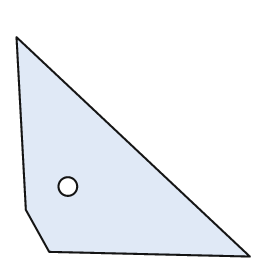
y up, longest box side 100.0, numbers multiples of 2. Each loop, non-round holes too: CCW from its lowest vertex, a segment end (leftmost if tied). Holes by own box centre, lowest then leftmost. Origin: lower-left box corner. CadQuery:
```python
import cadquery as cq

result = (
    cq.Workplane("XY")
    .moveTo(100.0, 0.0)
    .lineTo(0.0, 94.0)
    .lineTo(4.0, 20.0)
    .lineTo(14.0, 2.0)
    .close()
    .moveTo(22.0, 30.0)
    .circle(4.0)
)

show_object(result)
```